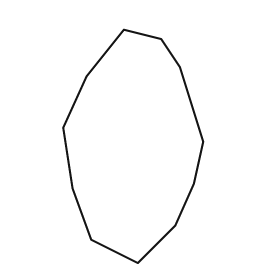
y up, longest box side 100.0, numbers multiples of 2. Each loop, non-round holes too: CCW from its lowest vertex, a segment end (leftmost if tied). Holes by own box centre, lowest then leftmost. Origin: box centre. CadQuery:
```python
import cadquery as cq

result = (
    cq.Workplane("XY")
    .moveTo(2.0, -50.0)
    .lineTo(18.0, -34.0)
    .lineTo(26.0, -16.0)
    .lineTo(30.0, 2.0)
    .lineTo(20.0, 34.0)
    .lineTo(12.0, 46.0)
    .lineTo(-4.0, 50.0)
    .lineTo(-20.0, 30.0)
    .lineTo(-30.0, 8.0)
    .lineTo(-26.0, -18.0)
    .lineTo(-18.0, -40.0)
    .close()
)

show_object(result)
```